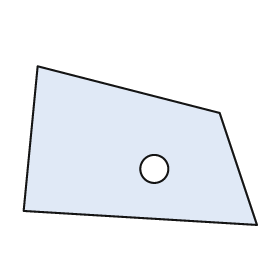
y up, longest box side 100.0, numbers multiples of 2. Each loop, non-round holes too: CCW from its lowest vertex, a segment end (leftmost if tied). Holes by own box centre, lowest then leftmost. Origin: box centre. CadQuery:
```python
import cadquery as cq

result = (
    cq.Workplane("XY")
    .moveTo(50.0, -34.0)
    .lineTo(34.0, 14.0)
    .lineTo(-44.0, 34.0)
    .lineTo(-50.0, -28.0)
    .close()
    .moveTo(6.0, -10.0)
    .circle(6.0)
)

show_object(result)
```